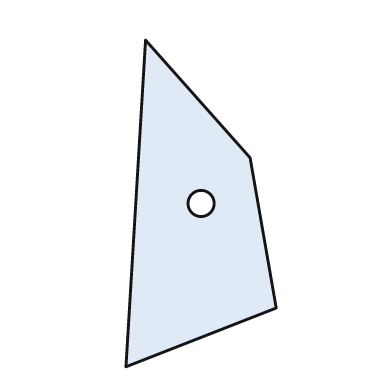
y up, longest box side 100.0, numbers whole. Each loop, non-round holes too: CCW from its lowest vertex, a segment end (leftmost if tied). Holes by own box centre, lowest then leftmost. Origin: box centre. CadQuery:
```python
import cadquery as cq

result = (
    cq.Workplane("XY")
    .moveTo(-23.0, -50.0)
    .lineTo(23.0, -32.0)
    .lineTo(15.0, 14.0)
    .lineTo(-17.0, 50.0)
    .close()
    .moveTo(0.0, 0.0)
    .circle(4.0)
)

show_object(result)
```